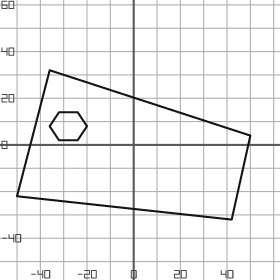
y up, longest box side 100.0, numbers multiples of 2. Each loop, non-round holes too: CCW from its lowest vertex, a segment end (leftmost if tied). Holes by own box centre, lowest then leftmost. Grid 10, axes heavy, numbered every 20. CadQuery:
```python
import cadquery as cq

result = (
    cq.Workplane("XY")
    .moveTo(42.0, -32.0)
    .lineTo(50.0, 4.0)
    .lineTo(-36.0, 32.0)
    .lineTo(-50.0, -22.0)
    .close()
    .moveTo(-32.0, 2.0)
    .lineTo(-24.0, 2.0)
    .lineTo(-20.0, 8.0)
    .lineTo(-24.0, 14.0)
    .lineTo(-32.0, 14.0)
    .lineTo(-36.0, 8.0)
    .close()
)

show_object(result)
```